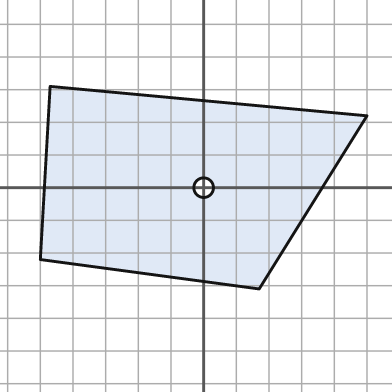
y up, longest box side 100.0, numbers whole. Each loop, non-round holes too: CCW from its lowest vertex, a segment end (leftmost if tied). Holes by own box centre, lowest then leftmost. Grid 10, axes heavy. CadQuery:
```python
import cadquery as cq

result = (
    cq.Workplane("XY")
    .moveTo(17.0, -31.0)
    .lineTo(50.0, 22.0)
    .lineTo(-47.0, 31.0)
    .lineTo(-50.0, -22.0)
    .close()
    .moveTo(0.0, 0.0)
    .circle(3.0)
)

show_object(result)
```